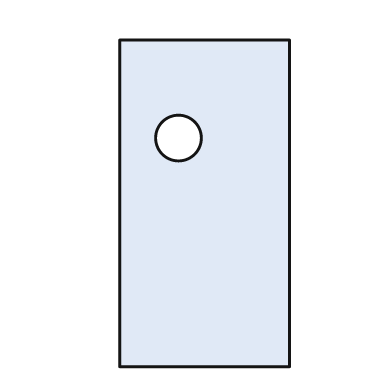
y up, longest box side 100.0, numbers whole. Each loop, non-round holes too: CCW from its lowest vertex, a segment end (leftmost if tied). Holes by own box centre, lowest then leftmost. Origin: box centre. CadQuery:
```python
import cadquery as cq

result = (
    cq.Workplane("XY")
    .moveTo(-26.0, -50.0)
    .lineTo(26.0, -50.0)
    .lineTo(26.0, 50.0)
    .lineTo(-26.0, 50.0)
    .close()
    .moveTo(-8.0, 20.0)
    .circle(7.0)
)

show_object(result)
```